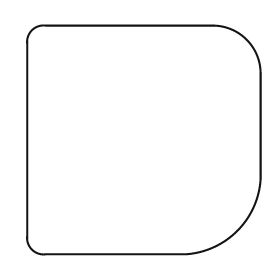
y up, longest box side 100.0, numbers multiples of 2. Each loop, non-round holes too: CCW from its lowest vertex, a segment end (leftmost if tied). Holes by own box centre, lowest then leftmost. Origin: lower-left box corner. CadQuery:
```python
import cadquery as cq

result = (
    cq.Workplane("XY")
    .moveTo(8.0, 0.0)
    .lineTo(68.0, 0.0)
    .threePointArc((90.0, 10.0), (100.0, 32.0))
    .lineTo(100.0, 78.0)
    .threePointArc((94.0, 92.0), (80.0, 98.0))
    .lineTo(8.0, 98.0)
    .threePointArc((2.0, 96.0), (0.0, 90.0))
    .lineTo(0.0, 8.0)
    .threePointArc((2.0, 2.0), (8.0, 0.0))
    .close()
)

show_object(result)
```